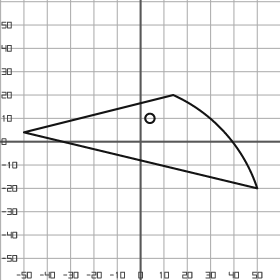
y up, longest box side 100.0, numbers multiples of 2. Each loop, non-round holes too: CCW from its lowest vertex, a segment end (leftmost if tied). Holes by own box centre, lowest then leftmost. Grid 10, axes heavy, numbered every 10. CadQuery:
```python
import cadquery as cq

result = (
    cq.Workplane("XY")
    .moveTo(50.0, -20.0)
    .threePointArc((36.0, 4.0), (14.0, 20.0))
    .lineTo(-50.0, 4.0)
    .close()
    .moveTo(4.0, 10.0)
    .circle(2.0)
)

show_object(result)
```